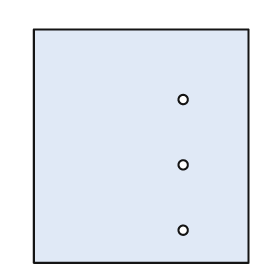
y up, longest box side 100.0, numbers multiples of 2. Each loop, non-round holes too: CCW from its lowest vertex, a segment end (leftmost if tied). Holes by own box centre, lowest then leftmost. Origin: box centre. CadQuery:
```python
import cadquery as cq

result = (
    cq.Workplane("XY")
    .moveTo(-46.0, -50.0)
    .lineTo(46.0, -50.0)
    .lineTo(46.0, 50.0)
    .lineTo(-46.0, 50.0)
    .close()
    .moveTo(18.0, -36.0)
    .circle(2.0)
    .moveTo(18.0, -8.0)
    .circle(2.0)
    .moveTo(18.0, 20.0)
    .circle(2.0)
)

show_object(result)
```